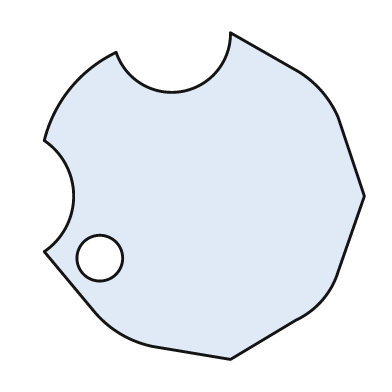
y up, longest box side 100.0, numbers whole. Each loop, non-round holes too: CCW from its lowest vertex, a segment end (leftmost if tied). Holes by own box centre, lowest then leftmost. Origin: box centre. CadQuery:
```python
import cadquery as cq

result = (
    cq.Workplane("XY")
    .moveTo(8.0, -50.0)
    .lineTo(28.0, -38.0)
    .threePointArc((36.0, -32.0), (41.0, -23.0))
    .lineTo(49.0, 0.0)
    .lineTo(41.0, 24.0)
    .threePointArc((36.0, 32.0), (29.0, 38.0))
    .lineTo(8.0, 50.0)
    .threePointArc((-7.0, 32.0), (-27.0, 44.0))
    .threePointArc((-41.0, 33.0), (-49.0, 17.0))
    .threePointArc((-40.0, 0.0), (-49.0, -17.0))
    .lineTo(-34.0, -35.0)
    .threePointArc((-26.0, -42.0), (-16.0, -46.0))
    .close()
    .moveTo(-32.0, -19.0)
    .circle(7.0)
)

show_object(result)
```